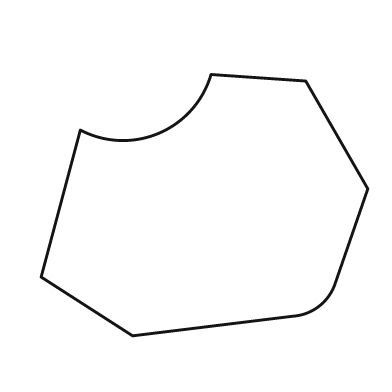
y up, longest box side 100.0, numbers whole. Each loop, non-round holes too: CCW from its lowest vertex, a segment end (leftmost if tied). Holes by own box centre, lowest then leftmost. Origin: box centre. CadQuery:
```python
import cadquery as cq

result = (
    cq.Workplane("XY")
    .moveTo(-22.0, -40.0)
    .lineTo(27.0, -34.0)
    .threePointArc((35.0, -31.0), (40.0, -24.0))
    .lineTo(50.0, 5.0)
    .lineTo(31.0, 38.0)
    .lineTo(2.0, 40.0)
    .threePointArc((-14.0, 22.0), (-38.0, 23.0))
    .lineTo(-50.0, -22.0)
    .close()
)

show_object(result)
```